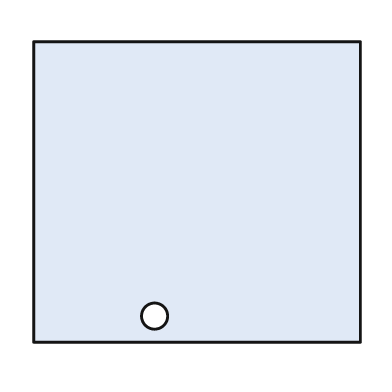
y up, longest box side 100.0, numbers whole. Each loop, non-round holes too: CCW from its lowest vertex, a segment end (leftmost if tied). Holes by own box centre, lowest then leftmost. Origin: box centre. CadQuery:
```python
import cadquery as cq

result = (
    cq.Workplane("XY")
    .moveTo(-50.0, -46.0)
    .lineTo(50.0, -46.0)
    .lineTo(50.0, 46.0)
    .lineTo(-50.0, 46.0)
    .close()
    .moveTo(-13.0, -38.0)
    .circle(4.0)
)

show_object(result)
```